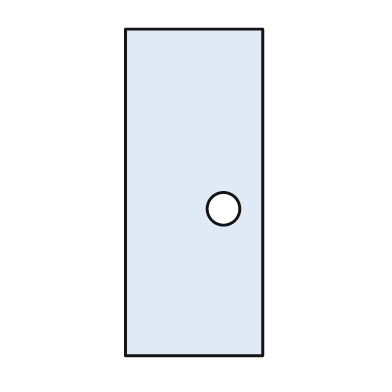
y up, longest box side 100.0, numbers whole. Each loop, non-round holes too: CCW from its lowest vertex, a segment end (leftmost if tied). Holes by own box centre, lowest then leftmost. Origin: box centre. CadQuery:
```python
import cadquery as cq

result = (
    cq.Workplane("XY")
    .moveTo(-21.0, -50.0)
    .lineTo(21.0, -50.0)
    .lineTo(21.0, 50.0)
    .lineTo(-21.0, 50.0)
    .close()
    .moveTo(9.0, -5.0)
    .circle(5.0)
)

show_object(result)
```